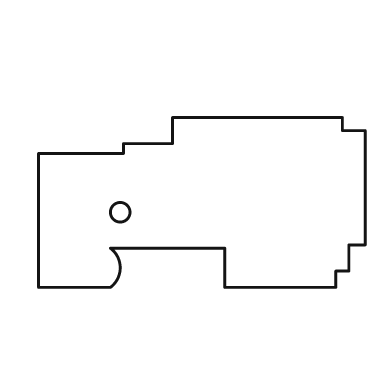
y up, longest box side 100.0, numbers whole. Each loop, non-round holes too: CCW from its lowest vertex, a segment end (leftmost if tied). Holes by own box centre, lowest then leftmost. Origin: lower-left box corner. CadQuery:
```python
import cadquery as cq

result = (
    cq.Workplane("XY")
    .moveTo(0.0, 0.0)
    .lineTo(22.0, 0.0)
    .threePointArc((25.0, 6.0), (22.0, 12.0))
    .lineTo(57.0, 12.0)
    .lineTo(57.0, 0.0)
    .lineTo(91.0, 0.0)
    .lineTo(91.0, 5.0)
    .lineTo(95.0, 5.0)
    .lineTo(95.0, 13.0)
    .lineTo(100.0, 13.0)
    .lineTo(100.0, 48.0)
    .lineTo(93.0, 48.0)
    .lineTo(93.0, 52.0)
    .lineTo(41.0, 52.0)
    .lineTo(41.0, 44.0)
    .lineTo(26.0, 44.0)
    .lineTo(26.0, 41.0)
    .lineTo(0.0, 41.0)
    .close()
    .moveTo(25.0, 23.0)
    .circle(3.0)
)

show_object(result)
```